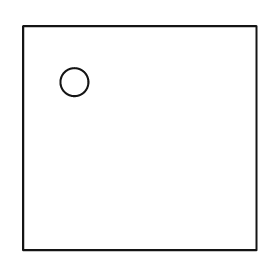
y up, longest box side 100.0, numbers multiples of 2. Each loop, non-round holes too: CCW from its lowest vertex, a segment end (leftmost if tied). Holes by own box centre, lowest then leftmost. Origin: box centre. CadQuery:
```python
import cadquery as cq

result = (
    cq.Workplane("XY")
    .moveTo(-50.0, -48.0)
    .lineTo(50.0, -48.0)
    .lineTo(50.0, 48.0)
    .lineTo(-50.0, 48.0)
    .close()
    .moveTo(-28.0, 24.0)
    .circle(6.0)
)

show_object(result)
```